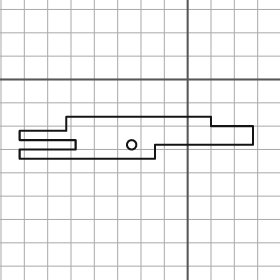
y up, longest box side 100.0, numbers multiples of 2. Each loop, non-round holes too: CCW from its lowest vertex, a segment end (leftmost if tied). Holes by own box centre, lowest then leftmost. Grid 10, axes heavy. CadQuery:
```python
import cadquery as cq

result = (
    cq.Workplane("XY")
    .moveTo(-72.0, -34.0)
    .lineTo(-14.0, -34.0)
    .lineTo(-14.0, -28.0)
    .lineTo(28.0, -28.0)
    .lineTo(28.0, -20.0)
    .lineTo(10.0, -20.0)
    .lineTo(10.0, -16.0)
    .lineTo(-52.0, -16.0)
    .lineTo(-52.0, -22.0)
    .lineTo(-72.0, -22.0)
    .lineTo(-72.0, -26.0)
    .lineTo(-48.0, -26.0)
    .lineTo(-48.0, -30.0)
    .lineTo(-72.0, -30.0)
    .close()
    .moveTo(-24.0, -28.0)
    .circle(2.0)
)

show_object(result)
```